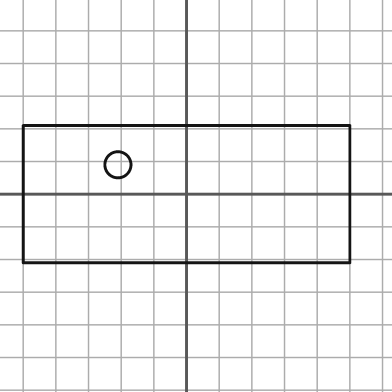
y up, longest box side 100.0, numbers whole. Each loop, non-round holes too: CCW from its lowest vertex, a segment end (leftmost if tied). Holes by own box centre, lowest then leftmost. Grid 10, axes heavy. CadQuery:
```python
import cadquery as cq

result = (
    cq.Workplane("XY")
    .moveTo(-50.0, -21.0)
    .lineTo(50.0, -21.0)
    .lineTo(50.0, 21.0)
    .lineTo(-50.0, 21.0)
    .close()
    .moveTo(-21.0, 9.0)
    .circle(4.0)
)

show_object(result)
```